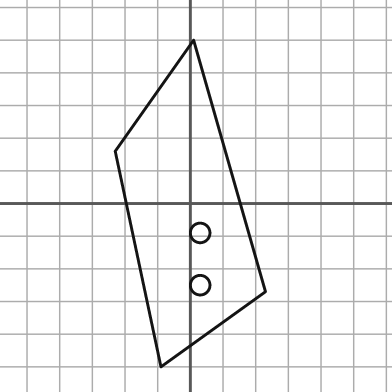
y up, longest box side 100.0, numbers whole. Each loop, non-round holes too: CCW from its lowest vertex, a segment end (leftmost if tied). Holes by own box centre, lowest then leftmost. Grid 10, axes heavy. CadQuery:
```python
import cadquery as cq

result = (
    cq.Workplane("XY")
    .moveTo(-9.0, -50.0)
    .lineTo(23.0, -27.0)
    .lineTo(1.0, 50.0)
    .lineTo(-23.0, 16.0)
    .close()
    .moveTo(3.0, -25.0)
    .circle(3.0)
    .moveTo(3.0, -9.0)
    .circle(3.0)
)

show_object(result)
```